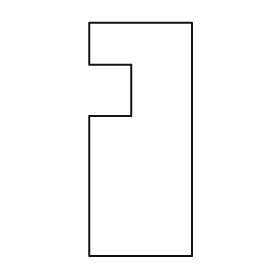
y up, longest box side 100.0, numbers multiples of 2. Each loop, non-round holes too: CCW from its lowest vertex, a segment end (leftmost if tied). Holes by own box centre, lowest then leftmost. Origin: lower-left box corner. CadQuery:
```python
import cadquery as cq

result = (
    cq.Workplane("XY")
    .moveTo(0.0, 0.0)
    .lineTo(44.0, 0.0)
    .lineTo(44.0, 100.0)
    .lineTo(0.0, 100.0)
    .lineTo(0.0, 82.0)
    .lineTo(18.0, 82.0)
    .lineTo(18.0, 60.0)
    .lineTo(0.0, 60.0)
    .close()
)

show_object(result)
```